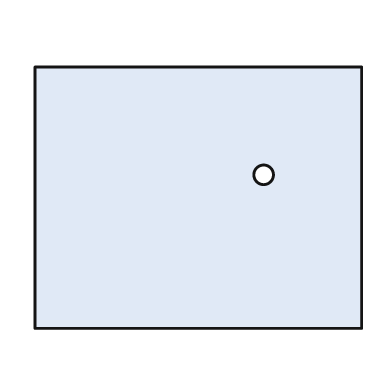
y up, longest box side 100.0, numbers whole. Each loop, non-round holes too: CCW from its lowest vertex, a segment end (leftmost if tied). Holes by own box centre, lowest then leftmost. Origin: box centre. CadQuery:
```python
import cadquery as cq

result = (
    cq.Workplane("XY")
    .moveTo(-50.0, -40.0)
    .lineTo(50.0, -40.0)
    .lineTo(50.0, 40.0)
    .lineTo(-50.0, 40.0)
    .close()
    .moveTo(20.0, 7.0)
    .circle(3.0)
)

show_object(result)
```